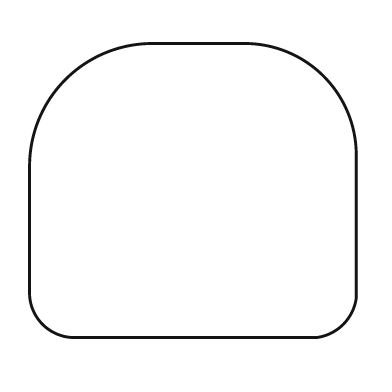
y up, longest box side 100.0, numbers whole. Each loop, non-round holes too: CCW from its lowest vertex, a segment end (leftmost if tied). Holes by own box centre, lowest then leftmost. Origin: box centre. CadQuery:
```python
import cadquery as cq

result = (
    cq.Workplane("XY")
    .moveTo(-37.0, -45.0)
    .lineTo(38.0, -45.0)
    .threePointArc((46.0, -41.0), (50.0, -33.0))
    .lineTo(50.0, 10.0)
    .threePointArc((40.0, 35.0), (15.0, 45.0))
    .lineTo(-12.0, 45.0)
    .threePointArc((-39.0, 34.0), (-50.0, 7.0))
    .lineTo(-50.0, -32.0)
    .threePointArc((-46.0, -41.0), (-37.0, -45.0))
    .close()
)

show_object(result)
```